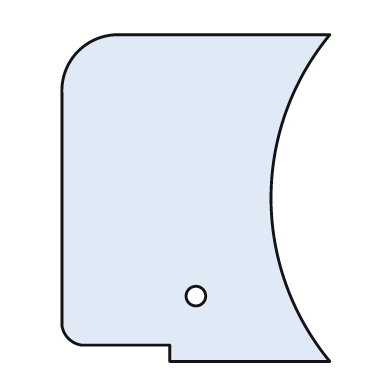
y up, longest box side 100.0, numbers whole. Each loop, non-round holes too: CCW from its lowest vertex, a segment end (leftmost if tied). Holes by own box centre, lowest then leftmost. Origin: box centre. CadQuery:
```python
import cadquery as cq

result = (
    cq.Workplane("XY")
    .moveTo(-8.0, -50.0)
    .lineTo(41.0, -50.0)
    .threePointArc((23.0, 0.0), (41.0, 50.0))
    .lineTo(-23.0, 50.0)
    .threePointArc((-36.0, 45.0), (-41.0, 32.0))
    .lineTo(-41.0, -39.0)
    .threePointArc((-39.0, -43.0), (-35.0, -45.0))
    .lineTo(-8.0, -45.0)
    .close()
    .moveTo(0.0, -30.0)
    .circle(3.0)
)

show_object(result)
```